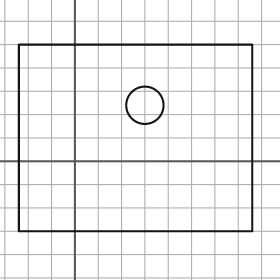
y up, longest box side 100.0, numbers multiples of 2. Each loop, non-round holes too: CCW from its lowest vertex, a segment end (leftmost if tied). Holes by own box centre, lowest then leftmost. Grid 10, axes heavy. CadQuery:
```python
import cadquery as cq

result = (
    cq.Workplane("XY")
    .moveTo(-24.0, -30.0)
    .lineTo(76.0, -30.0)
    .lineTo(76.0, 50.0)
    .lineTo(-24.0, 50.0)
    .close()
    .moveTo(30.0, 24.0)
    .circle(8.0)
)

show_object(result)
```